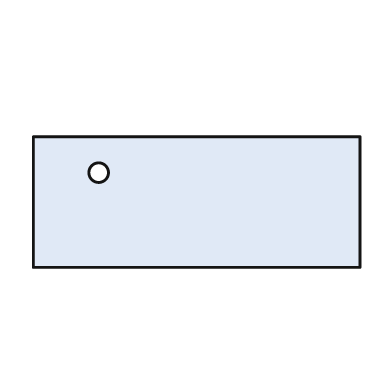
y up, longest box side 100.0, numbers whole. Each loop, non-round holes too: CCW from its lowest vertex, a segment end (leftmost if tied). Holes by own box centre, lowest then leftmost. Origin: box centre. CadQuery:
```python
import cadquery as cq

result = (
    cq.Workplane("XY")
    .moveTo(-50.0, -20.0)
    .lineTo(50.0, -20.0)
    .lineTo(50.0, 20.0)
    .lineTo(-50.0, 20.0)
    .close()
    .moveTo(-30.0, 9.0)
    .circle(3.0)
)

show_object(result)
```